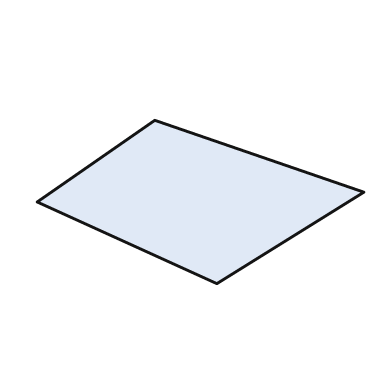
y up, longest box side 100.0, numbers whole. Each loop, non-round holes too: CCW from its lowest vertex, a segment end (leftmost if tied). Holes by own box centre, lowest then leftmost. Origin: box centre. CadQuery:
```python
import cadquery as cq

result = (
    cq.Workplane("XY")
    .moveTo(5.0, -25.0)
    .lineTo(50.0, 3.0)
    .lineTo(-14.0, 25.0)
    .lineTo(-50.0, 0.0)
    .close()
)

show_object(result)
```